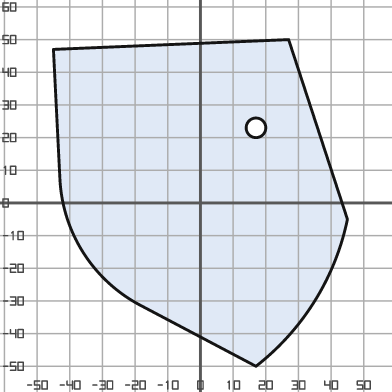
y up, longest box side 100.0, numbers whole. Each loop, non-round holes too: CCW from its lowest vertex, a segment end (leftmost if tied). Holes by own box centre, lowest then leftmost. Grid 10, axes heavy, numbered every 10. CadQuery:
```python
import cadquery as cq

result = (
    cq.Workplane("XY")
    .moveTo(17.0, -50.0)
    .threePointArc((35.0, -30.0), (45.0, -5.0))
    .lineTo(27.0, 50.0)
    .lineTo(-45.0, 47.0)
    .lineTo(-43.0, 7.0)
    .threePointArc((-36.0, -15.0), (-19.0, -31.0))
    .close()
    .moveTo(17.0, 23.0)
    .circle(3.0)
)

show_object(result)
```